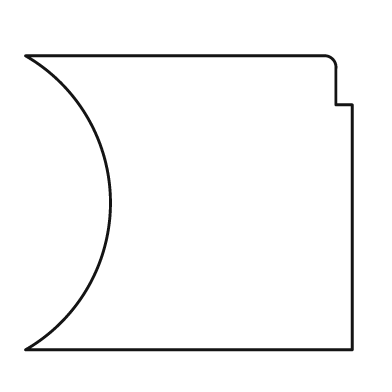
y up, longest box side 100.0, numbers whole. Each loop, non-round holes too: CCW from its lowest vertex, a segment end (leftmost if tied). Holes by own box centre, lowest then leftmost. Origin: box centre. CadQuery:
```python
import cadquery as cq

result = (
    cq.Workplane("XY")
    .moveTo(-50.0, -45.0)
    .lineTo(50.0, -45.0)
    .lineTo(50.0, 30.0)
    .lineTo(45.0, 30.0)
    .lineTo(45.0, 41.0)
    .threePointArc((44.0, 44.0), (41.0, 45.0))
    .lineTo(-50.0, 45.0)
    .threePointArc((-24.0, 0.0), (-50.0, -45.0))
    .close()
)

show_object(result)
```